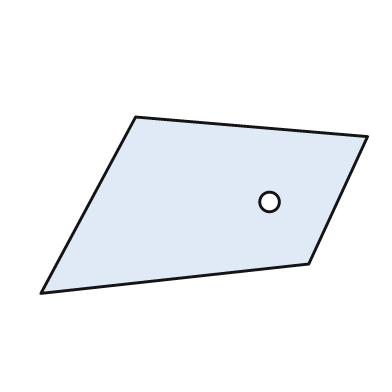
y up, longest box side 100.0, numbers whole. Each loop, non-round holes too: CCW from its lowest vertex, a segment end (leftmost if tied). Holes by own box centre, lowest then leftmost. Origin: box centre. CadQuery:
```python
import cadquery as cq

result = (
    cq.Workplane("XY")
    .moveTo(-50.0, -27.0)
    .lineTo(32.0, -18.0)
    .lineTo(50.0, 21.0)
    .lineTo(-21.0, 27.0)
    .close()
    .moveTo(20.0, 1.0)
    .circle(3.0)
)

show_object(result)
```